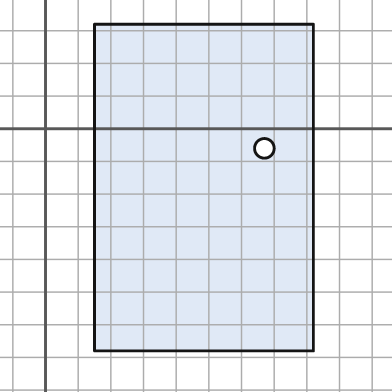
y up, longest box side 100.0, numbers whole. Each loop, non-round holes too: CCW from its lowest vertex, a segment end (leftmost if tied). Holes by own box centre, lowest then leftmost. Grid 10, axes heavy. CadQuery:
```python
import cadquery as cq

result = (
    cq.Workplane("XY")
    .moveTo(15.0, -68.0)
    .lineTo(82.0, -68.0)
    .lineTo(82.0, 32.0)
    .lineTo(15.0, 32.0)
    .close()
    .moveTo(67.0, -6.0)
    .circle(3.0)
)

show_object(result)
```